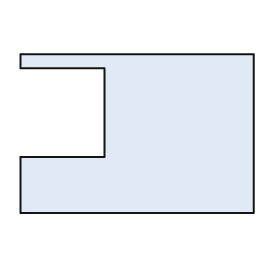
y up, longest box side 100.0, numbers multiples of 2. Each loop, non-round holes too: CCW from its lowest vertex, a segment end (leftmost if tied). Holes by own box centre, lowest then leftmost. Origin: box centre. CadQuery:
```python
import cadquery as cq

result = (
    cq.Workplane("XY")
    .moveTo(-50.0, -34.0)
    .lineTo(50.0, -34.0)
    .lineTo(50.0, 34.0)
    .lineTo(-50.0, 34.0)
    .lineTo(-50.0, 28.0)
    .lineTo(-14.0, 28.0)
    .lineTo(-14.0, -10.0)
    .lineTo(-50.0, -10.0)
    .close()
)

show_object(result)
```